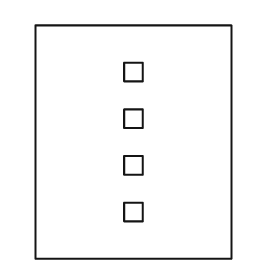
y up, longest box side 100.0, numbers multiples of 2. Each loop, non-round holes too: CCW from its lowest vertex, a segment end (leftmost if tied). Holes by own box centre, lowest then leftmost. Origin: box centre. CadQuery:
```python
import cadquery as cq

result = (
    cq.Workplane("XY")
    .moveTo(-42.0, -50.0)
    .lineTo(42.0, -50.0)
    .lineTo(42.0, 50.0)
    .lineTo(-42.0, 50.0)
    .close()
    .moveTo(-4.0, -34.0)
    .lineTo(4.0, -34.0)
    .lineTo(4.0, -26.0)
    .lineTo(-4.0, -26.0)
    .close()
    .moveTo(-4.0, -14.0)
    .lineTo(4.0, -14.0)
    .lineTo(4.0, -6.0)
    .lineTo(-4.0, -6.0)
    .close()
    .moveTo(-4.0, 6.0)
    .lineTo(4.0, 6.0)
    .lineTo(4.0, 14.0)
    .lineTo(-4.0, 14.0)
    .close()
    .moveTo(-4.0, 26.0)
    .lineTo(4.0, 26.0)
    .lineTo(4.0, 34.0)
    .lineTo(-4.0, 34.0)
    .close()
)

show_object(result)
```